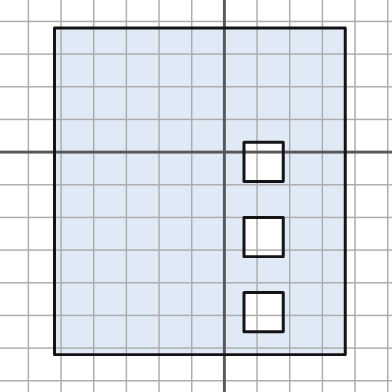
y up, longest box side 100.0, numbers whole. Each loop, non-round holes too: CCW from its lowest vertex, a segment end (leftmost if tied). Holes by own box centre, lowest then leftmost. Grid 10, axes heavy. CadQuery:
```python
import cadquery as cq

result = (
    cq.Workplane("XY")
    .moveTo(-52.0, -62.0)
    .lineTo(37.0, -62.0)
    .lineTo(37.0, 38.0)
    .lineTo(-52.0, 38.0)
    .close()
    .moveTo(6.0, -55.0)
    .lineTo(18.0, -55.0)
    .lineTo(18.0, -43.0)
    .lineTo(6.0, -43.0)
    .close()
    .moveTo(6.0, -32.0)
    .lineTo(18.0, -32.0)
    .lineTo(18.0, -20.0)
    .lineTo(6.0, -20.0)
    .close()
    .moveTo(6.0, -9.0)
    .lineTo(18.0, -9.0)
    .lineTo(18.0, 3.0)
    .lineTo(6.0, 3.0)
    .close()
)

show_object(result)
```